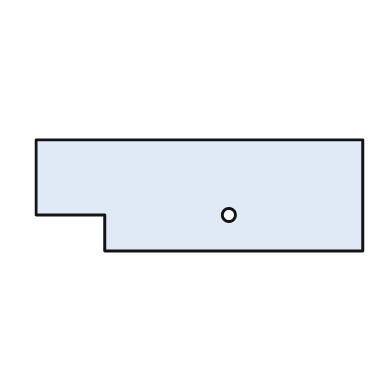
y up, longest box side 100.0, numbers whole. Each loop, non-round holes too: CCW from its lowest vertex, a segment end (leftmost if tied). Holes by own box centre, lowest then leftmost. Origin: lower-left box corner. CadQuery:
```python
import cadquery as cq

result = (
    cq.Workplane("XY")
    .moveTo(21.0, 0.0)
    .lineTo(100.0, 0.0)
    .lineTo(100.0, 34.0)
    .lineTo(0.0, 34.0)
    .lineTo(0.0, 11.0)
    .lineTo(21.0, 11.0)
    .close()
    .moveTo(59.0, 11.0)
    .circle(2.0)
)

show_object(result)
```